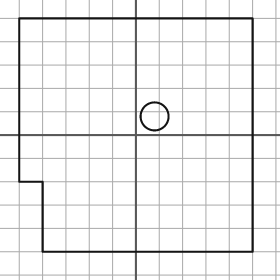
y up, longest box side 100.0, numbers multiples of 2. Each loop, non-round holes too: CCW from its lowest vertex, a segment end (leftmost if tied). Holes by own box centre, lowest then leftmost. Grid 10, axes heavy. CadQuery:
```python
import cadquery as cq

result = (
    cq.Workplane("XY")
    .moveTo(-40.0, -50.0)
    .lineTo(50.0, -50.0)
    .lineTo(50.0, 50.0)
    .lineTo(-50.0, 50.0)
    .lineTo(-50.0, -20.0)
    .lineTo(-40.0, -20.0)
    .close()
    .moveTo(8.0, 8.0)
    .circle(6.0)
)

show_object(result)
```